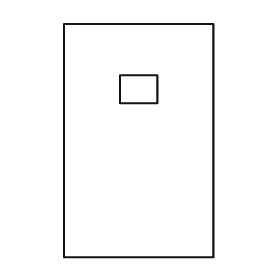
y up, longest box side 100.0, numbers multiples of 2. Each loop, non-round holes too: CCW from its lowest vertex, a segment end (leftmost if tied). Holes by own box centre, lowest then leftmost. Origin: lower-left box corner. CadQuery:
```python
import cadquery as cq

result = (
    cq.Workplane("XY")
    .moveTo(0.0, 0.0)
    .lineTo(64.0, 0.0)
    .lineTo(64.0, 100.0)
    .lineTo(0.0, 100.0)
    .close()
    .moveTo(24.0, 66.0)
    .lineTo(40.0, 66.0)
    .lineTo(40.0, 78.0)
    .lineTo(24.0, 78.0)
    .close()
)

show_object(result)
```